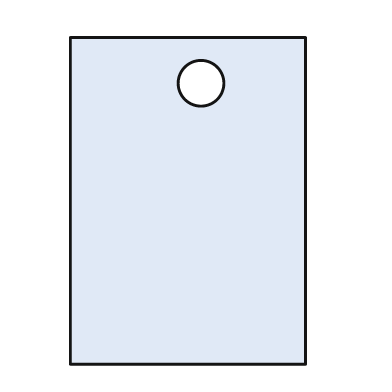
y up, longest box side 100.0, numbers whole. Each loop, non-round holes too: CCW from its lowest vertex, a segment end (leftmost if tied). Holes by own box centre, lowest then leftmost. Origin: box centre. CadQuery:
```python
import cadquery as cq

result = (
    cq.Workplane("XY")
    .moveTo(-36.0, -50.0)
    .lineTo(36.0, -50.0)
    .lineTo(36.0, 50.0)
    .lineTo(-36.0, 50.0)
    .close()
    .moveTo(4.0, 36.0)
    .circle(7.0)
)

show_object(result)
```